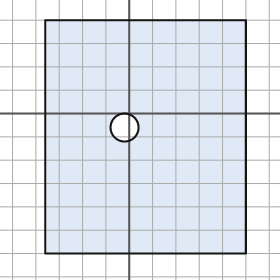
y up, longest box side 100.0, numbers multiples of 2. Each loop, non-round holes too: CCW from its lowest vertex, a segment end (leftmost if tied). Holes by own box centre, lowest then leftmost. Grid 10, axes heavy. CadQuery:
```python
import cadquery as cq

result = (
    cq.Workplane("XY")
    .moveTo(-36.0, -60.0)
    .lineTo(50.0, -60.0)
    .lineTo(50.0, 40.0)
    .lineTo(-36.0, 40.0)
    .close()
    .moveTo(-2.0, -6.0)
    .circle(6.0)
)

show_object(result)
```